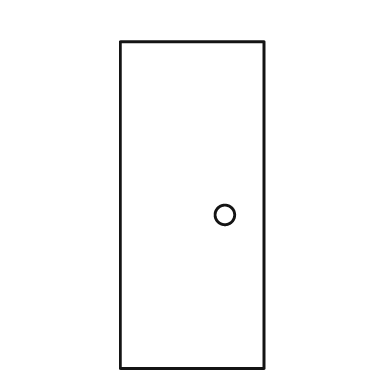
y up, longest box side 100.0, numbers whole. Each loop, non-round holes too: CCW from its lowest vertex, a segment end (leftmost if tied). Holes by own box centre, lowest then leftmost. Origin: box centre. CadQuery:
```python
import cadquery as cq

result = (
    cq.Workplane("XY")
    .moveTo(-22.0, -50.0)
    .lineTo(22.0, -50.0)
    .lineTo(22.0, 50.0)
    .lineTo(-22.0, 50.0)
    .close()
    .moveTo(10.0, -3.0)
    .circle(3.0)
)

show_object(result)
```